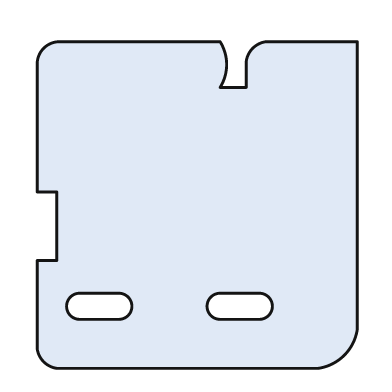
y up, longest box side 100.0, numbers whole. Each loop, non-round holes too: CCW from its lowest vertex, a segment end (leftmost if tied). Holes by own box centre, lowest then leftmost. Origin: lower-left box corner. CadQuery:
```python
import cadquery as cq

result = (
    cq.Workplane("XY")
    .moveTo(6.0, 0.0)
    .lineTo(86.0, 0.0)
    .threePointArc((94.0, 4.0), (98.0, 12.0))
    .lineTo(98.0, 100.0)
    .lineTo(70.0, 100.0)
    .threePointArc((66.0, 98.0), (64.0, 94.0))
    .lineTo(64.0, 86.0)
    .lineTo(56.0, 86.0)
    .threePointArc((58.0, 93.0), (56.0, 100.0))
    .lineTo(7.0, 100.0)
    .threePointArc((2.0, 98.0), (0.0, 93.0))
    .lineTo(0.0, 54.0)
    .lineTo(6.0, 54.0)
    .lineTo(6.0, 33.0)
    .lineTo(0.0, 33.0)
    .lineTo(0.0, 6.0)
    .threePointArc((2.0, 2.0), (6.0, 0.0))
    .close()
    .moveTo(13.0, 15.0)
    .lineTo(25.0, 15.0)
    .threePointArc((29.0, 19.0), (25.0, 23.0))
    .lineTo(13.0, 23.0)
    .threePointArc((9.0, 19.0), (13.0, 15.0))
    .close()
    .moveTo(56.0, 15.0)
    .lineTo(68.0, 15.0)
    .threePointArc((72.0, 19.0), (68.0, 23.0))
    .lineTo(56.0, 23.0)
    .threePointArc((52.0, 19.0), (56.0, 15.0))
    .close()
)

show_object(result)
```